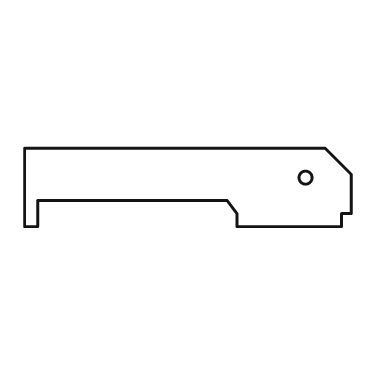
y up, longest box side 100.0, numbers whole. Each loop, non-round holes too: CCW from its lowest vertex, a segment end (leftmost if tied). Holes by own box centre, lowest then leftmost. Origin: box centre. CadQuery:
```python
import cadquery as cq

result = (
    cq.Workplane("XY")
    .moveTo(-50.0, -12.0)
    .lineTo(-46.0, -12.0)
    .lineTo(-46.0, -4.0)
    .lineTo(12.0, -4.0)
    .lineTo(15.0, -8.0)
    .lineTo(15.0, -12.0)
    .lineTo(47.0, -12.0)
    .lineTo(47.0, -8.0)
    .lineTo(50.0, -8.0)
    .lineTo(50.0, 4.0)
    .lineTo(42.0, 12.0)
    .lineTo(-50.0, 12.0)
    .close()
    .moveTo(36.0, 3.0)
    .circle(2.0)
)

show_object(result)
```